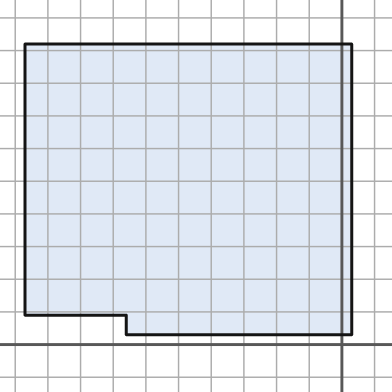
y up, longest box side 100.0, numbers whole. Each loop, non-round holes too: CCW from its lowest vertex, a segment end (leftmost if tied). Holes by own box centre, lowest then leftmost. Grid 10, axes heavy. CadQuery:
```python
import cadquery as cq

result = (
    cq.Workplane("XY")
    .moveTo(-66.0, 3.0)
    .lineTo(3.0, 3.0)
    .lineTo(3.0, 92.0)
    .lineTo(-97.0, 92.0)
    .lineTo(-97.0, 9.0)
    .lineTo(-66.0, 9.0)
    .close()
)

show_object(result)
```